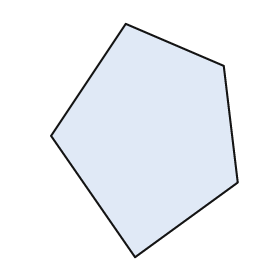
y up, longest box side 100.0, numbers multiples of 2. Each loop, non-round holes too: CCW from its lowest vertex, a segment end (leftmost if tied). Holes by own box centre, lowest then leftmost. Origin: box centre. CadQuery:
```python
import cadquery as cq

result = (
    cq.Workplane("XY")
    .moveTo(-4.0, -50.0)
    .lineTo(40.0, -18.0)
    .lineTo(34.0, 32.0)
    .lineTo(-8.0, 50.0)
    .lineTo(-40.0, 2.0)
    .close()
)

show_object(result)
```